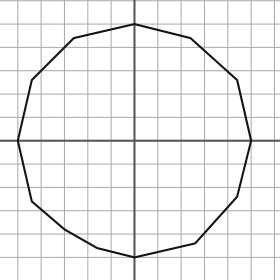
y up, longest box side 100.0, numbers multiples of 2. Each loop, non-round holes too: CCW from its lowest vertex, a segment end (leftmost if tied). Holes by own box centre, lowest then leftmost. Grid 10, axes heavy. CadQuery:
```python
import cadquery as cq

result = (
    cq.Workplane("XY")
    .moveTo(0.0, -50.0)
    .lineTo(26.0, -44.0)
    .lineTo(44.0, -24.0)
    .lineTo(50.0, 0.0)
    .lineTo(44.0, 26.0)
    .lineTo(24.0, 44.0)
    .lineTo(0.0, 50.0)
    .lineTo(-26.0, 44.0)
    .lineTo(-44.0, 26.0)
    .lineTo(-50.0, 0.0)
    .lineTo(-44.0, -26.0)
    .lineTo(-30.0, -38.0)
    .lineTo(-16.0, -46.0)
    .close()
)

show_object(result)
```